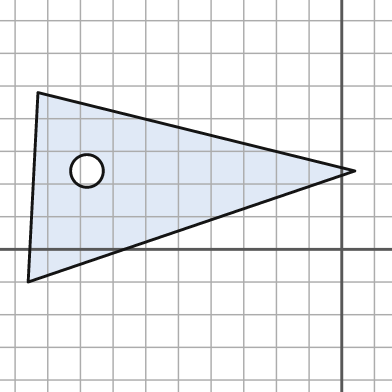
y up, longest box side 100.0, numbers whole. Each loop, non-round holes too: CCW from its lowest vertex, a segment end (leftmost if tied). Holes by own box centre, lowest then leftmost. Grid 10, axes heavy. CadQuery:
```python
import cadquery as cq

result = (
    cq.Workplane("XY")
    .moveTo(-96.0, -10.0)
    .lineTo(4.0, 24.0)
    .lineTo(-93.0, 48.0)
    .close()
    .moveTo(-78.0, 24.0)
    .circle(5.0)
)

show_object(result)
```